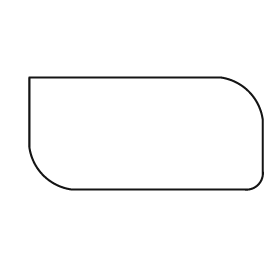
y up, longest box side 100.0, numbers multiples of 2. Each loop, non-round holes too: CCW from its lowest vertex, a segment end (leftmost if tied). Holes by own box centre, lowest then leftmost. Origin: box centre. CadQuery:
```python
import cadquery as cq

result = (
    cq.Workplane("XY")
    .moveTo(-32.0, -24.0)
    .lineTo(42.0, -24.0)
    .threePointArc((48.0, -22.0), (50.0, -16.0))
    .lineTo(50.0, 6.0)
    .threePointArc((44.0, 18.0), (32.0, 24.0))
    .lineTo(-50.0, 24.0)
    .lineTo(-50.0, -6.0)
    .threePointArc((-44.0, -18.0), (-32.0, -24.0))
    .close()
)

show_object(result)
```